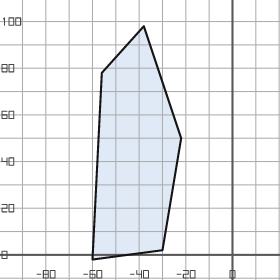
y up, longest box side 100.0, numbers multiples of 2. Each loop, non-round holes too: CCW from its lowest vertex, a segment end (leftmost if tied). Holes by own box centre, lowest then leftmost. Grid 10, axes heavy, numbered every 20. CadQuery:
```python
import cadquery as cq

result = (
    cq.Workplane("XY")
    .moveTo(-60.0, -2.0)
    .lineTo(-30.0, 2.0)
    .lineTo(-22.0, 50.0)
    .lineTo(-38.0, 98.0)
    .lineTo(-56.0, 78.0)
    .close()
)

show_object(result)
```